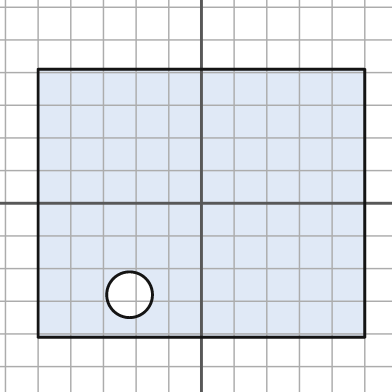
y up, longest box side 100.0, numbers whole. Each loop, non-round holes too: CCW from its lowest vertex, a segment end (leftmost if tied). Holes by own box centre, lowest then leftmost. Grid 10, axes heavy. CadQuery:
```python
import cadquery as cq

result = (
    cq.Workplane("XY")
    .moveTo(-50.0, -41.0)
    .lineTo(50.0, -41.0)
    .lineTo(50.0, 41.0)
    .lineTo(-50.0, 41.0)
    .close()
    .moveTo(-22.0, -28.0)
    .circle(7.0)
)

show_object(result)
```